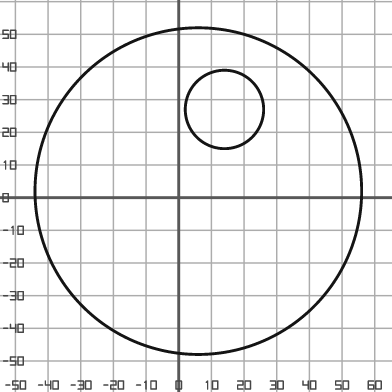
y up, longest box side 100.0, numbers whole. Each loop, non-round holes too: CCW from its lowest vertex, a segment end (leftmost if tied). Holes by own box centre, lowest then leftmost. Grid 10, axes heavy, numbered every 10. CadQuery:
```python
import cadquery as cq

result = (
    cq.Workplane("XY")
    .moveTo(6.0, 2.0)
    .circle(50.0)
    .moveTo(14.0, 27.0)
    .circle(12.0)
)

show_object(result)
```